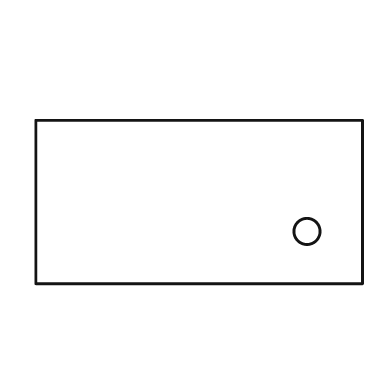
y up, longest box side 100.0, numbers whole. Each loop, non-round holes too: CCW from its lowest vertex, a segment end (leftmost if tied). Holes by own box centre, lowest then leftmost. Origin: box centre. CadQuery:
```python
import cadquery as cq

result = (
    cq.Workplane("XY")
    .moveTo(-50.0, -25.0)
    .lineTo(50.0, -25.0)
    .lineTo(50.0, 25.0)
    .lineTo(-50.0, 25.0)
    .close()
    .moveTo(33.0, -9.0)
    .circle(4.0)
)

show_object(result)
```